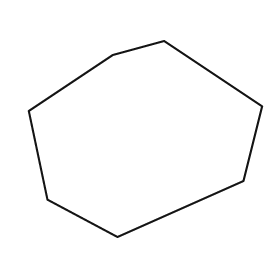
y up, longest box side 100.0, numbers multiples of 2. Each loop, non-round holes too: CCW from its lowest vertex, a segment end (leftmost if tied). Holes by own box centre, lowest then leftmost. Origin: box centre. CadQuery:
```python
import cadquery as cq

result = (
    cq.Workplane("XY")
    .moveTo(-12.0, -42.0)
    .lineTo(42.0, -18.0)
    .lineTo(50.0, 14.0)
    .lineTo(8.0, 42.0)
    .lineTo(-14.0, 36.0)
    .lineTo(-50.0, 12.0)
    .lineTo(-42.0, -26.0)
    .close()
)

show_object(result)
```